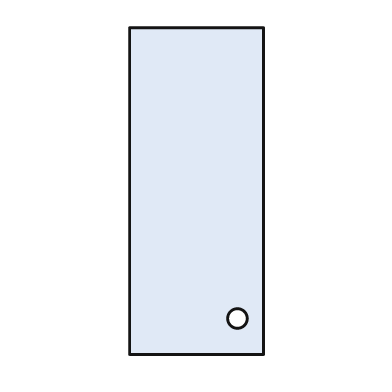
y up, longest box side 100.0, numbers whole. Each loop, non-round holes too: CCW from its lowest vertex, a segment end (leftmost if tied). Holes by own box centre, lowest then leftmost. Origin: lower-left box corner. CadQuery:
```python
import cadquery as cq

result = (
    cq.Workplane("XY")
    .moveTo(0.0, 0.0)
    .lineTo(41.0, 0.0)
    .lineTo(41.0, 100.0)
    .lineTo(0.0, 100.0)
    .close()
    .moveTo(33.0, 11.0)
    .circle(3.0)
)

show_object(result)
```